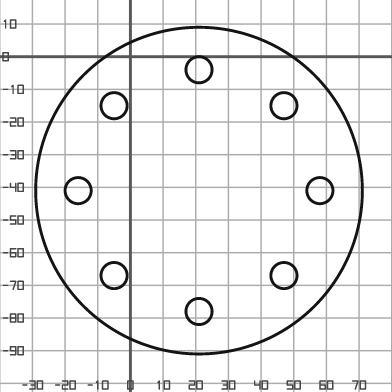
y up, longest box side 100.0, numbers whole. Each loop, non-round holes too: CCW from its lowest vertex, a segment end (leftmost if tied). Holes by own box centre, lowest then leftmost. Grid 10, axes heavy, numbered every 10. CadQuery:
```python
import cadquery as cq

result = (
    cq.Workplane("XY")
    .moveTo(21.0, -41.0)
    .circle(50.0)
    .moveTo(21.0, -78.0)
    .circle(4.0)
    .moveTo(-5.0, -67.0)
    .circle(4.0)
    .moveTo(47.0, -67.0)
    .circle(4.0)
    .moveTo(-16.0, -41.0)
    .circle(4.0)
    .moveTo(58.0, -41.0)
    .circle(4.0)
    .moveTo(-5.0, -15.0)
    .circle(4.0)
    .moveTo(47.0, -15.0)
    .circle(4.0)
    .moveTo(21.0, -4.0)
    .circle(4.0)
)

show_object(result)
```